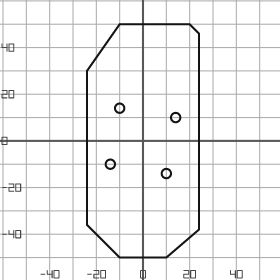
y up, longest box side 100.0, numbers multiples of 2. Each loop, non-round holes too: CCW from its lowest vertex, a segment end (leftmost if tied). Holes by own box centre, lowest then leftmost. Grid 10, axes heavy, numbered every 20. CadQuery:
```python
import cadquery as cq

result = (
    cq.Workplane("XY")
    .moveTo(-10.0, -50.0)
    .lineTo(10.0, -50.0)
    .lineTo(24.0, -38.0)
    .lineTo(24.0, 46.0)
    .lineTo(20.0, 50.0)
    .lineTo(-10.0, 50.0)
    .lineTo(-24.0, 30.0)
    .lineTo(-24.0, -36.0)
    .close()
    .moveTo(10.0, -14.0)
    .circle(2.0)
    .moveTo(-14.0, -10.0)
    .circle(2.0)
    .moveTo(14.0, 10.0)
    .circle(2.0)
    .moveTo(-10.0, 14.0)
    .circle(2.0)
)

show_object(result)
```